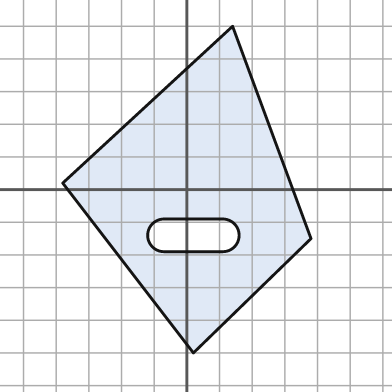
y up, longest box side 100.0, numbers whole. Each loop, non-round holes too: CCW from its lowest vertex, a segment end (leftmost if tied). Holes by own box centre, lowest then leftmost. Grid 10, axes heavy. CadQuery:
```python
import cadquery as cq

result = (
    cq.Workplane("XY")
    .moveTo(2.0, -50.0)
    .lineTo(38.0, -15.0)
    .lineTo(14.0, 50.0)
    .lineTo(-38.0, 2.0)
    .close()
    .moveTo(-7.0, -19.0)
    .lineTo(11.0, -19.0)
    .threePointArc((16.0, -14.0), (11.0, -9.0))
    .lineTo(-7.0, -9.0)
    .threePointArc((-12.0, -14.0), (-7.0, -19.0))
    .close()
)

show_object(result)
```